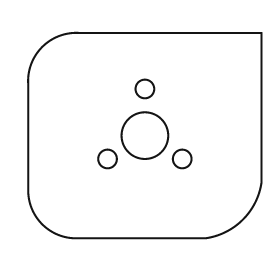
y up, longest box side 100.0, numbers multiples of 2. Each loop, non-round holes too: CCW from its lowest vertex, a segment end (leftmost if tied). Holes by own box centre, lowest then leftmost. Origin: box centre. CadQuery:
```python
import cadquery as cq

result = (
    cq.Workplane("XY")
    .moveTo(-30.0, -44.0)
    .lineTo(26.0, -44.0)
    .threePointArc((42.0, -36.0), (50.0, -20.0))
    .lineTo(50.0, 44.0)
    .lineTo(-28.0, 44.0)
    .threePointArc((-44.0, 38.0), (-50.0, 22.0))
    .lineTo(-50.0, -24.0)
    .threePointArc((-44.0, -38.0), (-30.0, -44.0))
    .close()
    .moveTo(-16.0, -10.0)
    .circle(4.0)
    .moveTo(16.0, -10.0)
    .circle(4.0)
    .moveTo(0.0, 0.0)
    .circle(10.0)
    .moveTo(0.0, 20.0)
    .circle(4.0)
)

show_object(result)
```